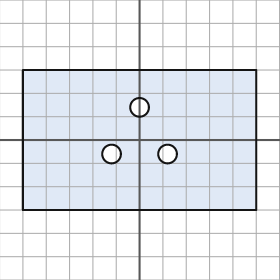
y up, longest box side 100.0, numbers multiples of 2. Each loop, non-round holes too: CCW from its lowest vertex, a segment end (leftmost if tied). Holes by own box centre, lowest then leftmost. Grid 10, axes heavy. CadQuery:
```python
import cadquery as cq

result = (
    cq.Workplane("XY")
    .moveTo(-50.0, -30.0)
    .lineTo(50.0, -30.0)
    .lineTo(50.0, 30.0)
    .lineTo(-50.0, 30.0)
    .close()
    .moveTo(-12.0, -6.0)
    .circle(4.0)
    .moveTo(12.0, -6.0)
    .circle(4.0)
    .moveTo(0.0, 14.0)
    .circle(4.0)
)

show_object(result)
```